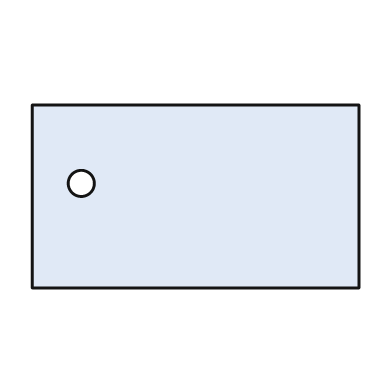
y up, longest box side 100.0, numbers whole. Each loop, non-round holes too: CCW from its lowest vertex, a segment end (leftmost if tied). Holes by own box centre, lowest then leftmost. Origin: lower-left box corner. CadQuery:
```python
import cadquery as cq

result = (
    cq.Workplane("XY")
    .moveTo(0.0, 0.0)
    .lineTo(100.0, 0.0)
    .lineTo(100.0, 56.0)
    .lineTo(0.0, 56.0)
    .close()
    .moveTo(15.0, 32.0)
    .circle(4.0)
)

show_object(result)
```